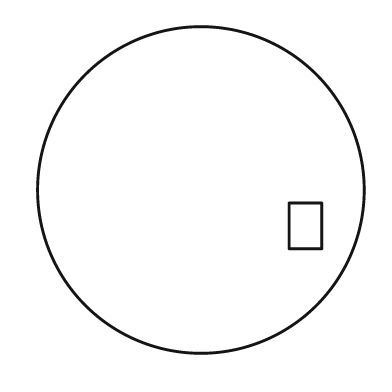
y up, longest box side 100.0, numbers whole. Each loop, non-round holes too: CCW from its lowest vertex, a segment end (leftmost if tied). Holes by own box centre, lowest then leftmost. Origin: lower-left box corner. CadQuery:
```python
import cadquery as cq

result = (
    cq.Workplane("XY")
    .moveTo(50.0, 50.0)
    .circle(50.0)
    .moveTo(77.0, 32.0)
    .lineTo(87.0, 32.0)
    .lineTo(87.0, 46.0)
    .lineTo(77.0, 46.0)
    .close()
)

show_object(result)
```